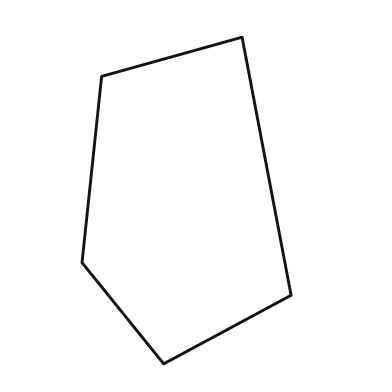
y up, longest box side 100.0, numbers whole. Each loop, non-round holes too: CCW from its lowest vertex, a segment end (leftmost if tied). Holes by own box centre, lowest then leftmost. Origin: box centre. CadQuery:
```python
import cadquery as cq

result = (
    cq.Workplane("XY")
    .moveTo(-7.0, -50.0)
    .lineTo(32.0, -29.0)
    .lineTo(17.0, 50.0)
    .lineTo(-26.0, 38.0)
    .lineTo(-32.0, -19.0)
    .close()
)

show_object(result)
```